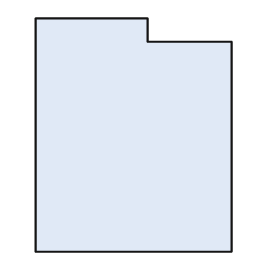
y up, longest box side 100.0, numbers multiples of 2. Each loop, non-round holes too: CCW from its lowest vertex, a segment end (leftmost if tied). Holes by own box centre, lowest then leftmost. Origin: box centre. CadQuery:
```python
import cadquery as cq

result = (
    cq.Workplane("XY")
    .moveTo(-42.0, -50.0)
    .lineTo(42.0, -50.0)
    .lineTo(42.0, 40.0)
    .lineTo(6.0, 40.0)
    .lineTo(6.0, 50.0)
    .lineTo(-42.0, 50.0)
    .close()
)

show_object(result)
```